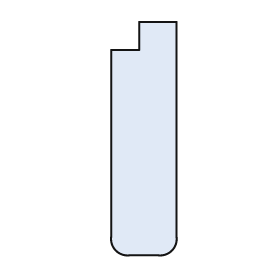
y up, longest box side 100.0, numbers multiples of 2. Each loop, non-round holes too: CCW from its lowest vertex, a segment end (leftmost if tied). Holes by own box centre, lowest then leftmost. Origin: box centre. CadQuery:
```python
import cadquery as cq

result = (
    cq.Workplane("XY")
    .moveTo(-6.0, -50.0)
    .lineTo(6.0, -50.0)
    .threePointArc((12.0, -48.0), (14.0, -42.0))
    .lineTo(14.0, 50.0)
    .lineTo(-2.0, 50.0)
    .lineTo(-2.0, 38.0)
    .lineTo(-14.0, 38.0)
    .lineTo(-14.0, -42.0)
    .threePointArc((-12.0, -48.0), (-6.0, -50.0))
    .close()
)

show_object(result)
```